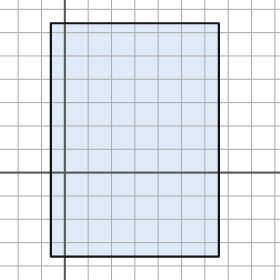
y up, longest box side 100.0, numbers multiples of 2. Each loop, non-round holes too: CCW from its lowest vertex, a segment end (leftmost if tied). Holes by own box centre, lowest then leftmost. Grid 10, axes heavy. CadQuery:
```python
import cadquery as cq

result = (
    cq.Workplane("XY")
    .moveTo(-6.0, -36.0)
    .lineTo(66.0, -36.0)
    .lineTo(66.0, 64.0)
    .lineTo(-6.0, 64.0)
    .close()
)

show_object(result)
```